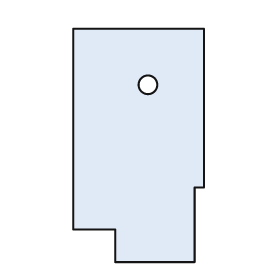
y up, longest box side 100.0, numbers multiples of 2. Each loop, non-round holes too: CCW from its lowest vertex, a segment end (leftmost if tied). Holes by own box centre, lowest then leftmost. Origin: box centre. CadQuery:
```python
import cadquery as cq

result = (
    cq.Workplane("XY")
    .moveTo(-10.0, -50.0)
    .lineTo(24.0, -50.0)
    .lineTo(24.0, -18.0)
    .lineTo(28.0, -18.0)
    .lineTo(28.0, 50.0)
    .lineTo(-28.0, 50.0)
    .lineTo(-28.0, -36.0)
    .lineTo(-10.0, -36.0)
    .close()
    .moveTo(4.0, 26.0)
    .circle(4.0)
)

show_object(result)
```